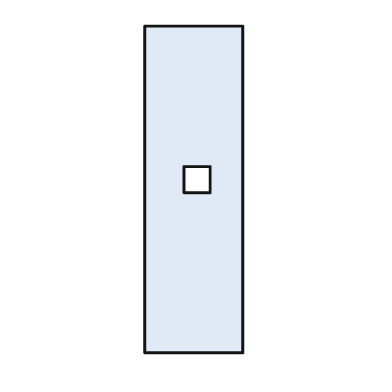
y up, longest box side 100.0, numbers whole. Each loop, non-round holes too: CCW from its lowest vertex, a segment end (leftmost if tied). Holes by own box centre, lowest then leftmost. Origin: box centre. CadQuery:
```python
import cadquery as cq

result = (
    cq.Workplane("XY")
    .moveTo(-15.0, -50.0)
    .lineTo(15.0, -50.0)
    .lineTo(15.0, 50.0)
    .lineTo(-15.0, 50.0)
    .close()
    .moveTo(-3.0, -1.0)
    .lineTo(5.0, -1.0)
    .lineTo(5.0, 7.0)
    .lineTo(-3.0, 7.0)
    .close()
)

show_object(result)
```